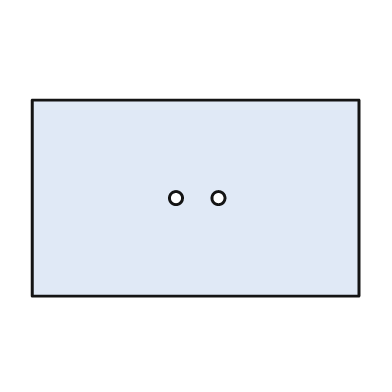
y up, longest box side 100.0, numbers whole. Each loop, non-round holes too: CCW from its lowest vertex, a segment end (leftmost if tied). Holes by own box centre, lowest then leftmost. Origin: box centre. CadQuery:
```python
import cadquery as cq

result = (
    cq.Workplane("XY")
    .moveTo(-50.0, -30.0)
    .lineTo(50.0, -30.0)
    .lineTo(50.0, 30.0)
    .lineTo(-50.0, 30.0)
    .close()
    .moveTo(-6.0, 0.0)
    .circle(2.0)
    .moveTo(7.0, 0.0)
    .circle(2.0)
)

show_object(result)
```